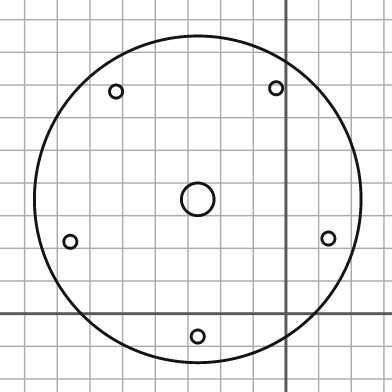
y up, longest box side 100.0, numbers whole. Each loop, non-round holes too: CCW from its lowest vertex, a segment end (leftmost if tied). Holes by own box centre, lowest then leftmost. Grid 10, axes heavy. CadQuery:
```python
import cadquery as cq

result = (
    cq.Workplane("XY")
    .moveTo(-27.0, 35.0)
    .circle(50.0)
    .moveTo(-27.0, -7.0)
    .circle(2.0)
    .moveTo(-66.0, 22.0)
    .circle(2.0)
    .moveTo(13.0, 23.0)
    .circle(2.0)
    .moveTo(-27.0, 35.0)
    .circle(5.0)
    .moveTo(-52.0, 68.0)
    .circle(2.0)
    .moveTo(-3.0, 69.0)
    .circle(2.0)
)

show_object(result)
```